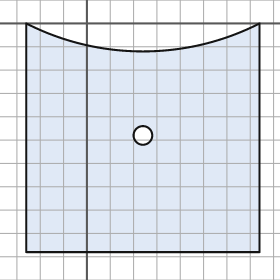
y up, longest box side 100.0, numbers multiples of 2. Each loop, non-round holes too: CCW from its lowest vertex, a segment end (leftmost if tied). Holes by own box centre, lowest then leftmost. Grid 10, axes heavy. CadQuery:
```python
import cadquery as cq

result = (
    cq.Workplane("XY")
    .moveTo(-26.0, -98.0)
    .lineTo(74.0, -98.0)
    .lineTo(74.0, 0.0)
    .threePointArc((24.0, -12.0), (-26.0, 0.0))
    .close()
    .moveTo(24.0, -48.0)
    .circle(4.0)
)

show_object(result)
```